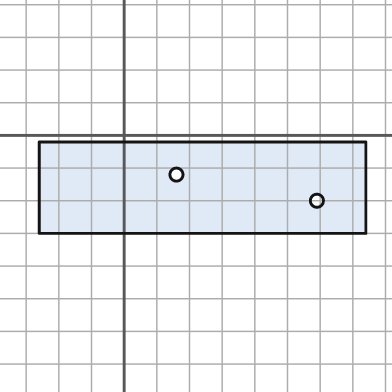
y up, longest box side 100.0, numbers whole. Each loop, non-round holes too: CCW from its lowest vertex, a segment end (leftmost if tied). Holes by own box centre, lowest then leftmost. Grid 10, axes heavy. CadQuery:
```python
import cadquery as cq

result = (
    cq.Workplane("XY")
    .moveTo(-26.0, -30.0)
    .lineTo(74.0, -30.0)
    .lineTo(74.0, -2.0)
    .lineTo(-26.0, -2.0)
    .close()
    .moveTo(59.0, -20.0)
    .circle(2.0)
    .moveTo(16.0, -12.0)
    .circle(2.0)
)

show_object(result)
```